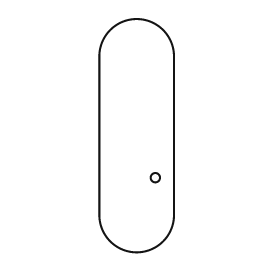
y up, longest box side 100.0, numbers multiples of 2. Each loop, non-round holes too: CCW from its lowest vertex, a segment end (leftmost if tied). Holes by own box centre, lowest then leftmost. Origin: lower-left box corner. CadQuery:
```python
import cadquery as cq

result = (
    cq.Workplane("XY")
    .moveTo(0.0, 16.0)
    .threePointArc((16.0, 0.0), (32.0, 16.0))
    .lineTo(32.0, 84.0)
    .threePointArc((16.0, 100.0), (0.0, 84.0))
    .close()
    .moveTo(24.0, 32.0)
    .circle(2.0)
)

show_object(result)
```